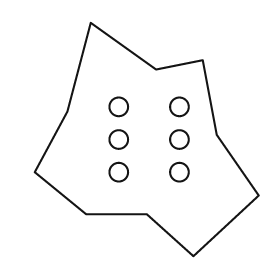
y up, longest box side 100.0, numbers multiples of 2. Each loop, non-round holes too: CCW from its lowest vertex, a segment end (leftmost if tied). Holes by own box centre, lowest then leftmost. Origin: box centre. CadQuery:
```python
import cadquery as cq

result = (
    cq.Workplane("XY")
    .moveTo(20.0, -50.0)
    .lineTo(48.0, -24.0)
    .lineTo(30.0, 2.0)
    .lineTo(24.0, 34.0)
    .lineTo(4.0, 30.0)
    .lineTo(-24.0, 50.0)
    .lineTo(-34.0, 12.0)
    .lineTo(-48.0, -14.0)
    .lineTo(-26.0, -32.0)
    .lineTo(0.0, -32.0)
    .close()
    .moveTo(-12.0, -14.0)
    .circle(4.0)
    .moveTo(14.0, -14.0)
    .circle(4.0)
    .moveTo(-12.0, 0.0)
    .circle(4.0)
    .moveTo(14.0, 0.0)
    .circle(4.0)
    .moveTo(-12.0, 14.0)
    .circle(4.0)
    .moveTo(14.0, 14.0)
    .circle(4.0)
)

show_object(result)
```